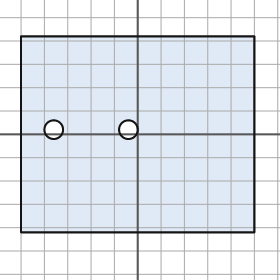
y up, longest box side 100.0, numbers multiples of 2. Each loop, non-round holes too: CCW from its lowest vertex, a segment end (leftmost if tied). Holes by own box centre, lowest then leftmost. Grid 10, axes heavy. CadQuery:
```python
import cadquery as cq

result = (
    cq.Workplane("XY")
    .moveTo(-50.0, -42.0)
    .lineTo(50.0, -42.0)
    .lineTo(50.0, 42.0)
    .lineTo(-50.0, 42.0)
    .close()
    .moveTo(-36.0, 2.0)
    .circle(4.0)
    .moveTo(-4.0, 2.0)
    .circle(4.0)
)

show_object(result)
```